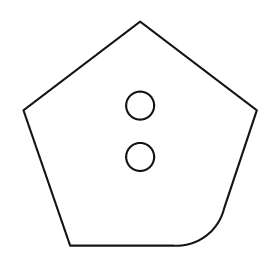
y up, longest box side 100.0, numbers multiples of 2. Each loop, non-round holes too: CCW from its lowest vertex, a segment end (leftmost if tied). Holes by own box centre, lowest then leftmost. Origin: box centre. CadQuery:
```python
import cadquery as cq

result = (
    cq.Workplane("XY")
    .moveTo(-30.0, -48.0)
    .lineTo(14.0, -48.0)
    .threePointArc((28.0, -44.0), (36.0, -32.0))
    .lineTo(50.0, 10.0)
    .lineTo(0.0, 48.0)
    .lineTo(-50.0, 10.0)
    .close()
    .moveTo(0.0, -10.0)
    .circle(6.0)
    .moveTo(0.0, 12.0)
    .circle(6.0)
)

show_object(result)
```